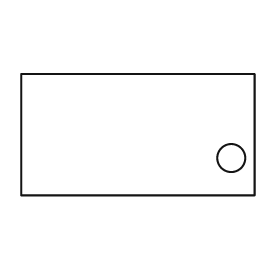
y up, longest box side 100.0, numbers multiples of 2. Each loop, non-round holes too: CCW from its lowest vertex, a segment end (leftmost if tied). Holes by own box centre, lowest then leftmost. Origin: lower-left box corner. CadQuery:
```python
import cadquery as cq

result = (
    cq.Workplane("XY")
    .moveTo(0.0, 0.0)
    .lineTo(100.0, 0.0)
    .lineTo(100.0, 52.0)
    .lineTo(0.0, 52.0)
    .close()
    .moveTo(90.0, 16.0)
    .circle(6.0)
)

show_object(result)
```